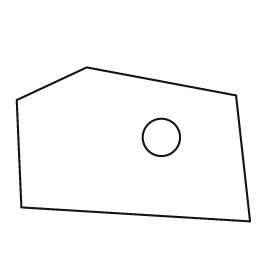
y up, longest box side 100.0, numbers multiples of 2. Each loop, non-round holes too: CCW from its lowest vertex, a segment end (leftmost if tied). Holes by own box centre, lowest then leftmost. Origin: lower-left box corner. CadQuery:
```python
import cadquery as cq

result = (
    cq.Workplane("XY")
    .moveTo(100.0, 0.0)
    .lineTo(94.0, 54.0)
    .lineTo(30.0, 66.0)
    .lineTo(0.0, 52.0)
    .lineTo(2.0, 6.0)
    .close()
    .moveTo(62.0, 36.0)
    .circle(8.0)
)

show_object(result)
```